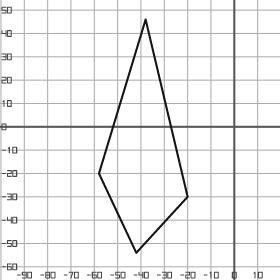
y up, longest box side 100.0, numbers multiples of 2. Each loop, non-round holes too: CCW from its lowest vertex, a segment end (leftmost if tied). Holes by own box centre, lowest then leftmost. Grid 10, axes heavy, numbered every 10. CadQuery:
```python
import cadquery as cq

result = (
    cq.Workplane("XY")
    .moveTo(-42.0, -54.0)
    .lineTo(-20.0, -30.0)
    .lineTo(-38.0, 46.0)
    .lineTo(-58.0, -20.0)
    .close()
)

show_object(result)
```